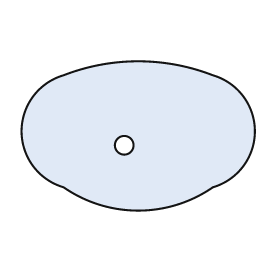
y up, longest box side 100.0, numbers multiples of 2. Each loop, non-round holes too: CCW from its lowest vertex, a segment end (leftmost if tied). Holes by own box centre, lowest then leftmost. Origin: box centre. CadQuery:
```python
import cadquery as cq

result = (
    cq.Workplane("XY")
    .moveTo(-32.0, -22.0)
    .threePointArc((0.0, -32.0), (32.0, -22.0))
    .threePointArc((50.0, 2.0), (32.0, 26.0))
    .threePointArc((0.0, 32.0), (-32.0, 26.0))
    .threePointArc((-50.0, 2.0), (-32.0, -22.0))
    .close()
    .moveTo(-6.0, -4.0)
    .circle(4.0)
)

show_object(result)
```